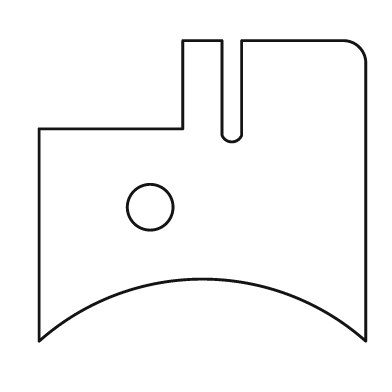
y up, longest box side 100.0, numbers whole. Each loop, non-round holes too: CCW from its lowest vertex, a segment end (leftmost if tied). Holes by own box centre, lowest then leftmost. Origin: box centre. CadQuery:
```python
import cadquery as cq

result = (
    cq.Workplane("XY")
    .moveTo(-50.0, -46.0)
    .threePointArc((0.0, -27.0), (50.0, -46.0))
    .lineTo(50.0, 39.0)
    .threePointArc((48.0, 44.0), (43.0, 46.0))
    .lineTo(12.0, 46.0)
    .lineTo(12.0, 17.0)
    .threePointArc((9.0, 15.0), (6.0, 17.0))
    .lineTo(6.0, 46.0)
    .lineTo(-6.0, 46.0)
    .lineTo(-6.0, 19.0)
    .lineTo(-50.0, 19.0)
    .close()
    .moveTo(-16.0, -5.0)
    .circle(7.0)
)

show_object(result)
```